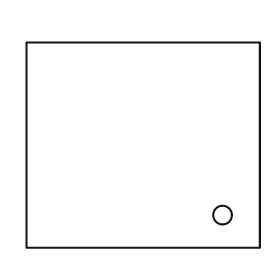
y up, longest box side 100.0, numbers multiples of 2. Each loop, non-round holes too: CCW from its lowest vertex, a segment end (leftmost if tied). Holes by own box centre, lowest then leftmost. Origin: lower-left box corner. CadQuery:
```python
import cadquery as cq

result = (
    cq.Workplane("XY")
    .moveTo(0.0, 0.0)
    .lineTo(100.0, 0.0)
    .lineTo(100.0, 88.0)
    .lineTo(0.0, 88.0)
    .close()
    .moveTo(84.0, 14.0)
    .circle(4.0)
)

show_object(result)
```